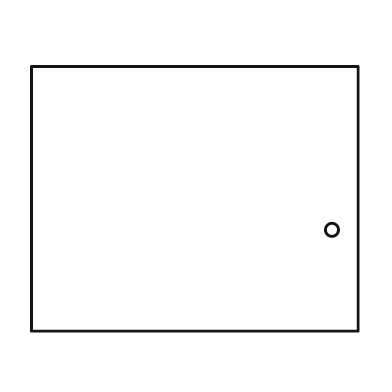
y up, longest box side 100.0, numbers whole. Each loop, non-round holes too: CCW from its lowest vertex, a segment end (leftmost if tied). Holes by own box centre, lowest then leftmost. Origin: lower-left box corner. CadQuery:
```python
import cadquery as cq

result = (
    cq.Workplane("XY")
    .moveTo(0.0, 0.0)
    .lineTo(100.0, 0.0)
    .lineTo(100.0, 81.0)
    .lineTo(0.0, 81.0)
    .close()
    .moveTo(92.0, 31.0)
    .circle(2.0)
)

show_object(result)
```